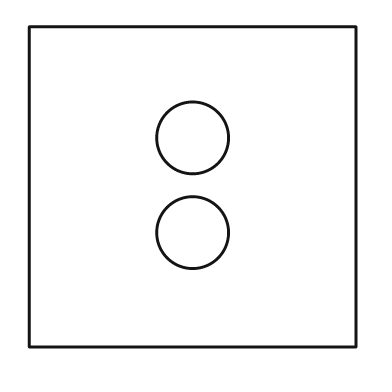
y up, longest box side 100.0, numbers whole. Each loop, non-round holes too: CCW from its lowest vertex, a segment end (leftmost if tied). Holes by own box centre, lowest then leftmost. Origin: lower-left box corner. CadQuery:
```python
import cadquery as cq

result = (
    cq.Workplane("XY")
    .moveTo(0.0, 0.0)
    .lineTo(100.0, 0.0)
    .lineTo(100.0, 98.0)
    .lineTo(0.0, 98.0)
    .close()
    .moveTo(50.0, 35.0)
    .circle(11.0)
    .moveTo(50.0, 64.0)
    .circle(11.0)
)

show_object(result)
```